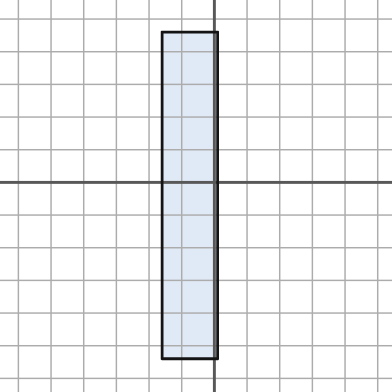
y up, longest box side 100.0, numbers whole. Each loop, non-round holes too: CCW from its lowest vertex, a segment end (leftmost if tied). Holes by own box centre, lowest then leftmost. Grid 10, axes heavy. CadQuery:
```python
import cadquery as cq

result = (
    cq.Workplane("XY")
    .moveTo(-16.0, -54.0)
    .lineTo(1.0, -54.0)
    .lineTo(1.0, 46.0)
    .lineTo(-16.0, 46.0)
    .close()
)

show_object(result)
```